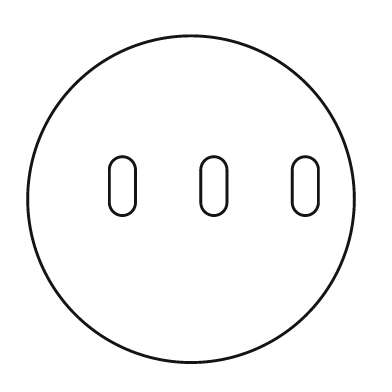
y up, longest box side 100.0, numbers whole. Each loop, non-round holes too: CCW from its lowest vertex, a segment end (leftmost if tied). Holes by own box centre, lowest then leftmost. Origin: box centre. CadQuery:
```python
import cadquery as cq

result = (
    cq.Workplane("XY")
    .moveTo(0.0, 0.0)
    .circle(50.0)
    .moveTo(-25.0, -1.0)
    .threePointArc((-21.0, -5.0), (-17.0, -1.0))
    .lineTo(-17.0, 9.0)
    .threePointArc((-21.0, 13.0), (-25.0, 9.0))
    .close()
    .moveTo(3.0, -1.0)
    .threePointArc((7.0, -5.0), (11.0, -1.0))
    .lineTo(11.0, 9.0)
    .threePointArc((7.0, 13.0), (3.0, 9.0))
    .close()
    .moveTo(31.0, -1.0)
    .threePointArc((35.0, -5.0), (39.0, -1.0))
    .lineTo(39.0, 9.0)
    .threePointArc((35.0, 13.0), (31.0, 9.0))
    .close()
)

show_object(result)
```